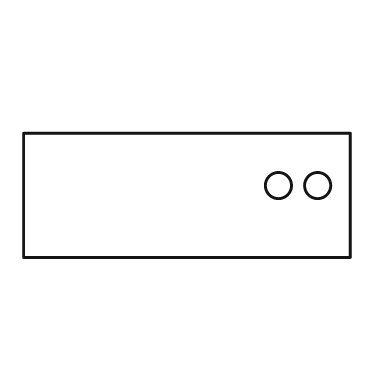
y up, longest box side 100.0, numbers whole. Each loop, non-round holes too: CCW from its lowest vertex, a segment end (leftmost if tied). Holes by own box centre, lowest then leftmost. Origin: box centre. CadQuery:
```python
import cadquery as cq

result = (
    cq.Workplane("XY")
    .moveTo(-50.0, -19.0)
    .lineTo(50.0, -19.0)
    .lineTo(50.0, 19.0)
    .lineTo(-50.0, 19.0)
    .close()
    .moveTo(28.0, 3.0)
    .circle(4.0)
    .moveTo(40.0, 3.0)
    .circle(4.0)
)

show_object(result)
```